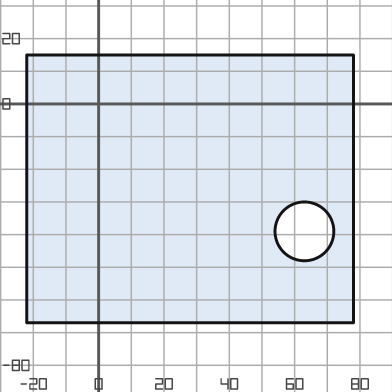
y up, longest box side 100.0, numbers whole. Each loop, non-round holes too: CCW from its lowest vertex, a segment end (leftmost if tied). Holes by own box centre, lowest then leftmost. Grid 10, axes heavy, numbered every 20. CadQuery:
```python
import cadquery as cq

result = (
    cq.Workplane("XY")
    .moveTo(-22.0, -67.0)
    .lineTo(78.0, -67.0)
    .lineTo(78.0, 15.0)
    .lineTo(-22.0, 15.0)
    .close()
    .moveTo(63.0, -39.0)
    .circle(9.0)
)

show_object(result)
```